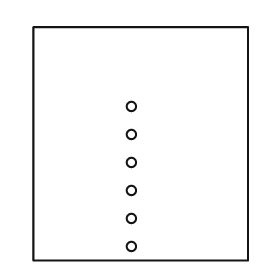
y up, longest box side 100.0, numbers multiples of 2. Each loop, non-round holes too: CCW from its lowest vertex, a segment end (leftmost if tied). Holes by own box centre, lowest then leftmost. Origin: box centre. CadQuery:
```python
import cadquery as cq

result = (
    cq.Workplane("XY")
    .moveTo(-46.0, -50.0)
    .lineTo(46.0, -50.0)
    .lineTo(46.0, 50.0)
    .lineTo(-46.0, 50.0)
    .close()
    .moveTo(-4.0, -44.0)
    .circle(2.0)
    .moveTo(-4.0, -32.0)
    .circle(2.0)
    .moveTo(-4.0, -20.0)
    .circle(2.0)
    .moveTo(-4.0, -8.0)
    .circle(2.0)
    .moveTo(-4.0, 4.0)
    .circle(2.0)
    .moveTo(-4.0, 16.0)
    .circle(2.0)
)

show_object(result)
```